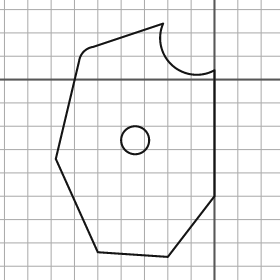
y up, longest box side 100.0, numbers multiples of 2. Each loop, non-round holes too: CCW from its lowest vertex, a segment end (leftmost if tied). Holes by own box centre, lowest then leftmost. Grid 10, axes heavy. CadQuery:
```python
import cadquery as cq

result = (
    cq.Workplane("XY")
    .moveTo(-20.0, -76.0)
    .lineTo(0.0, -50.0)
    .lineTo(0.0, 4.0)
    .threePointArc((-18.0, 6.0), (-22.0, 24.0))
    .lineTo(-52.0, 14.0)
    .threePointArc((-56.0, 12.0), (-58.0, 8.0))
    .lineTo(-68.0, -34.0)
    .lineTo(-50.0, -74.0)
    .close()
    .moveTo(-34.0, -26.0)
    .circle(6.0)
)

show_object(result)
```